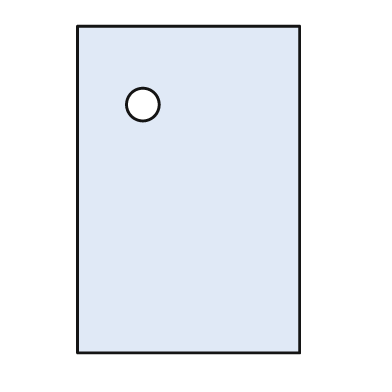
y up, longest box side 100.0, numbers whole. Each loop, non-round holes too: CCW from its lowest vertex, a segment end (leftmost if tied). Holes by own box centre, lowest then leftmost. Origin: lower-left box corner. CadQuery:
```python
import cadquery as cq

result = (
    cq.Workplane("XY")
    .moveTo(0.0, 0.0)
    .lineTo(68.0, 0.0)
    .lineTo(68.0, 100.0)
    .lineTo(0.0, 100.0)
    .close()
    .moveTo(20.0, 76.0)
    .circle(5.0)
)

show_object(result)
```